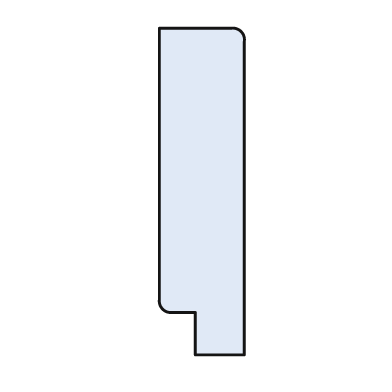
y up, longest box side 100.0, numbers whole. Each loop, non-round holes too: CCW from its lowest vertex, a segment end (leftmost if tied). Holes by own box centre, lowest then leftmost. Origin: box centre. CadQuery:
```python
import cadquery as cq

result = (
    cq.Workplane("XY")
    .moveTo(-2.0, -50.0)
    .lineTo(13.0, -50.0)
    .lineTo(13.0, 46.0)
    .threePointArc((12.0, 49.0), (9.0, 50.0))
    .lineTo(-13.0, 50.0)
    .lineTo(-13.0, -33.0)
    .threePointArc((-12.0, -36.0), (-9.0, -37.0))
    .lineTo(-2.0, -37.0)
    .close()
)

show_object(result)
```